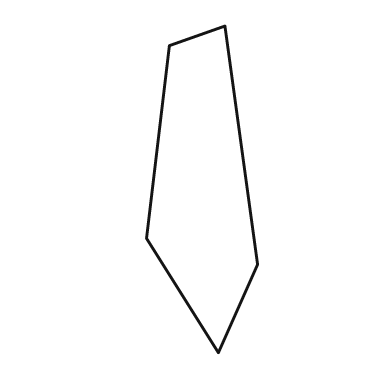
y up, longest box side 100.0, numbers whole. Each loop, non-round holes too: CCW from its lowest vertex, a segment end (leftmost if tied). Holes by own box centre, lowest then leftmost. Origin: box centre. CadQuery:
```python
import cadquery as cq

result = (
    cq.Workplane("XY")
    .moveTo(5.0, -50.0)
    .lineTo(17.0, -23.0)
    .lineTo(7.0, 50.0)
    .lineTo(-10.0, 44.0)
    .lineTo(-17.0, -15.0)
    .close()
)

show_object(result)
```